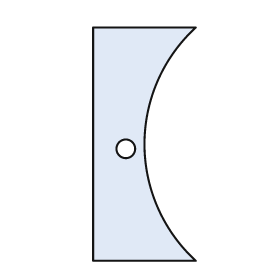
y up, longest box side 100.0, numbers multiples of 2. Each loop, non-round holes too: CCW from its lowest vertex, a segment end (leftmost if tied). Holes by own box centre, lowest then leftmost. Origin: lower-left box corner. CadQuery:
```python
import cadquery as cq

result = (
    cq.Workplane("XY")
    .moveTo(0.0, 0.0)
    .lineTo(44.0, 0.0)
    .threePointArc((22.0, 50.0), (44.0, 100.0))
    .lineTo(0.0, 100.0)
    .close()
    .moveTo(14.0, 48.0)
    .circle(4.0)
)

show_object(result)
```